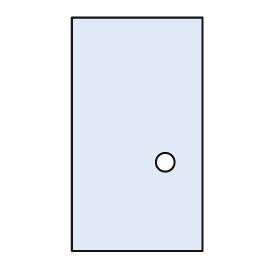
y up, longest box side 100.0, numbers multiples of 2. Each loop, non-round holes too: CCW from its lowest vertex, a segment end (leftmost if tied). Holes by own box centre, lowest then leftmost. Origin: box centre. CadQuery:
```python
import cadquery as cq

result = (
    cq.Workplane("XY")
    .moveTo(-28.0, -50.0)
    .lineTo(28.0, -50.0)
    .lineTo(28.0, 50.0)
    .lineTo(-28.0, 50.0)
    .close()
    .moveTo(12.0, -12.0)
    .circle(4.0)
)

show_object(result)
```